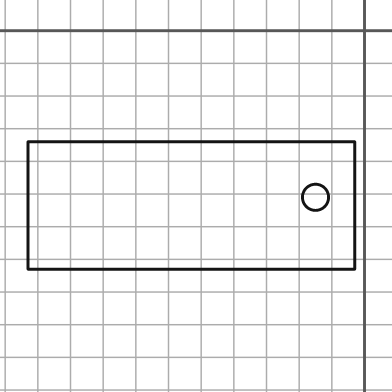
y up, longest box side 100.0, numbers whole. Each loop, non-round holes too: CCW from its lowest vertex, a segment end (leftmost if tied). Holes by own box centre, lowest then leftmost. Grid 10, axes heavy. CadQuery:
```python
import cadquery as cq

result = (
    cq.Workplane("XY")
    .moveTo(-103.0, -73.0)
    .lineTo(-3.0, -73.0)
    .lineTo(-3.0, -34.0)
    .lineTo(-103.0, -34.0)
    .close()
    .moveTo(-15.0, -51.0)
    .circle(4.0)
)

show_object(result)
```